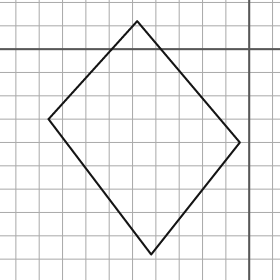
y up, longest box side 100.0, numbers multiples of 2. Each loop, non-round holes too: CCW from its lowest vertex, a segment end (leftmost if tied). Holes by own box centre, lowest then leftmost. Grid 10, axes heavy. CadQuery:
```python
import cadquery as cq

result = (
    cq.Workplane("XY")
    .moveTo(-42.0, -88.0)
    .lineTo(-4.0, -40.0)
    .lineTo(-48.0, 12.0)
    .lineTo(-86.0, -30.0)
    .close()
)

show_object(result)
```